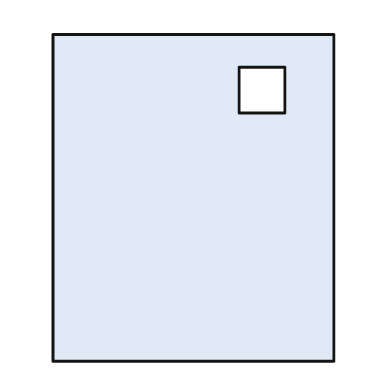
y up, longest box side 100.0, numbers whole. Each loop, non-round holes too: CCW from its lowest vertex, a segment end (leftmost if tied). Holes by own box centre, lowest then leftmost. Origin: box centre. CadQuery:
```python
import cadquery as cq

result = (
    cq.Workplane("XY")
    .moveTo(-43.0, -50.0)
    .lineTo(43.0, -50.0)
    .lineTo(43.0, 50.0)
    .lineTo(-43.0, 50.0)
    .close()
    .moveTo(14.0, 26.0)
    .lineTo(28.0, 26.0)
    .lineTo(28.0, 40.0)
    .lineTo(14.0, 40.0)
    .close()
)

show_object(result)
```